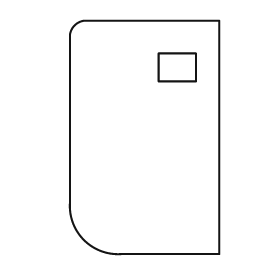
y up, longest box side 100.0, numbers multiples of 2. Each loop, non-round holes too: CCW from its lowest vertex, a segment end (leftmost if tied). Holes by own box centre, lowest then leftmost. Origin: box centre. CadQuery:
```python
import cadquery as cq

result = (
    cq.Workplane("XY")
    .moveTo(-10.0, -50.0)
    .lineTo(32.0, -50.0)
    .lineTo(32.0, 50.0)
    .lineTo(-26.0, 50.0)
    .threePointArc((-30.0, 48.0), (-32.0, 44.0))
    .lineTo(-32.0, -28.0)
    .threePointArc((-26.0, -44.0), (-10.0, -50.0))
    .close()
    .moveTo(6.0, 24.0)
    .lineTo(22.0, 24.0)
    .lineTo(22.0, 36.0)
    .lineTo(6.0, 36.0)
    .close()
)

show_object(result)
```